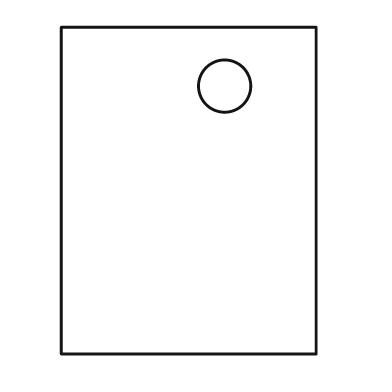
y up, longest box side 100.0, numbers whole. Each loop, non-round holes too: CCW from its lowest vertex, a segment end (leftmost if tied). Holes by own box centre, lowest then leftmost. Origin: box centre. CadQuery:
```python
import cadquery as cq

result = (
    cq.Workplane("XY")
    .moveTo(-39.0, -50.0)
    .lineTo(39.0, -50.0)
    .lineTo(39.0, 50.0)
    .lineTo(-39.0, 50.0)
    .close()
    .moveTo(11.0, 32.0)
    .circle(8.0)
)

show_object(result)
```